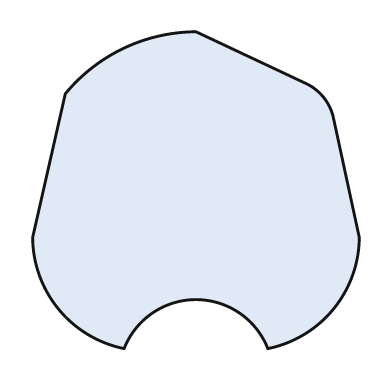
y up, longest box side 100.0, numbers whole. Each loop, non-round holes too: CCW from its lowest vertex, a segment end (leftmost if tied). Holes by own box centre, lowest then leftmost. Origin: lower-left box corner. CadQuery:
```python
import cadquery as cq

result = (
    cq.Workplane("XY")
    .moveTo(28.0, 0.0)
    .threePointArc((50.0, 15.0), (72.0, 0.0))
    .threePointArc((92.0, 12.0), (100.0, 34.0))
    .lineTo(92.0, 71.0)
    .threePointArc((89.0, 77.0), (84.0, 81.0))
    .lineTo(50.0, 97.0)
    .threePointArc((28.0, 92.0), (10.0, 78.0))
    .lineTo(0.0, 34.0)
    .threePointArc((8.0, 12.0), (28.0, 0.0))
    .close()
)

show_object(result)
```